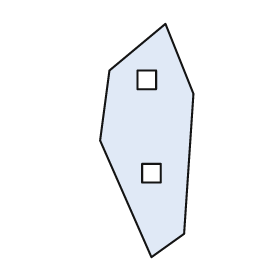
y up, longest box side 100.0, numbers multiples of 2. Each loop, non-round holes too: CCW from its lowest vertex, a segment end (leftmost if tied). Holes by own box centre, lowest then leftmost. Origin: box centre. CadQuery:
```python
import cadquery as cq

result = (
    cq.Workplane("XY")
    .moveTo(2.0, -50.0)
    .lineTo(16.0, -40.0)
    .lineTo(20.0, 20.0)
    .lineTo(8.0, 50.0)
    .lineTo(-16.0, 30.0)
    .lineTo(-20.0, 0.0)
    .close()
    .moveTo(-2.0, -18.0)
    .lineTo(6.0, -18.0)
    .lineTo(6.0, -10.0)
    .lineTo(-2.0, -10.0)
    .close()
    .moveTo(-4.0, 22.0)
    .lineTo(4.0, 22.0)
    .lineTo(4.0, 30.0)
    .lineTo(-4.0, 30.0)
    .close()
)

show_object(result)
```